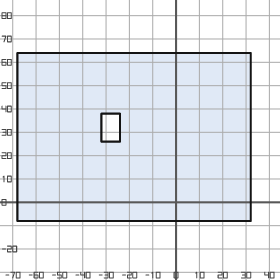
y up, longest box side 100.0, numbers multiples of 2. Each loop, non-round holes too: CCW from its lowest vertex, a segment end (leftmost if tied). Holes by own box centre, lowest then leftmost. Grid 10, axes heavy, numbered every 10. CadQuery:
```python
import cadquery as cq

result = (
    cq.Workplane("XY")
    .moveTo(-68.0, -8.0)
    .lineTo(32.0, -8.0)
    .lineTo(32.0, 64.0)
    .lineTo(-68.0, 64.0)
    .close()
    .moveTo(-32.0, 26.0)
    .lineTo(-24.0, 26.0)
    .lineTo(-24.0, 38.0)
    .lineTo(-32.0, 38.0)
    .close()
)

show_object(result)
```